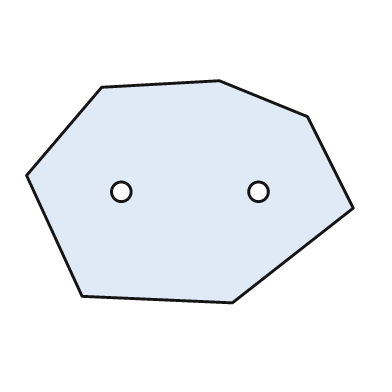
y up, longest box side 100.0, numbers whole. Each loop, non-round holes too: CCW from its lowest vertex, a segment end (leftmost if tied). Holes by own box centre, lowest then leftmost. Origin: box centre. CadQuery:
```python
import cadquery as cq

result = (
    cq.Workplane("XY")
    .moveTo(13.0, -34.0)
    .lineTo(50.0, -5.0)
    .lineTo(36.0, 23.0)
    .lineTo(9.0, 34.0)
    .lineTo(-27.0, 32.0)
    .lineTo(-50.0, 5.0)
    .lineTo(-33.0, -32.0)
    .close()
    .moveTo(-21.0, 0.0)
    .circle(3.0)
    .moveTo(21.0, 0.0)
    .circle(3.0)
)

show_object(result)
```